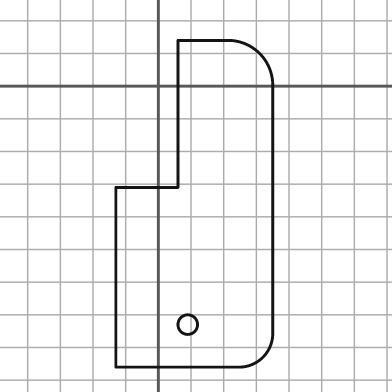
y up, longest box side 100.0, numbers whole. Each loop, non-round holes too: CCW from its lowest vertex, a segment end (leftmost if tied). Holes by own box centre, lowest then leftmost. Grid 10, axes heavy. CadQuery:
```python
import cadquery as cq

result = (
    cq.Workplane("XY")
    .moveTo(-13.0, -86.0)
    .lineTo(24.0, -86.0)
    .threePointArc((32.0, -83.0), (35.0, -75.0))
    .lineTo(35.0, 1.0)
    .threePointArc((31.0, 10.0), (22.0, 14.0))
    .lineTo(6.0, 14.0)
    .lineTo(6.0, -31.0)
    .lineTo(-13.0, -31.0)
    .close()
    .moveTo(9.0, -73.0)
    .circle(3.0)
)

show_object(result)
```